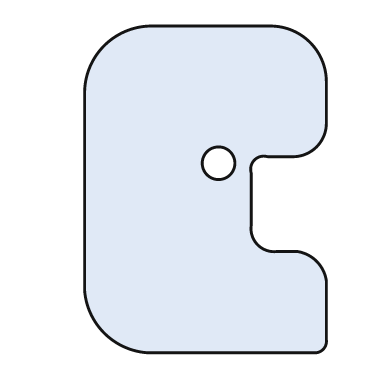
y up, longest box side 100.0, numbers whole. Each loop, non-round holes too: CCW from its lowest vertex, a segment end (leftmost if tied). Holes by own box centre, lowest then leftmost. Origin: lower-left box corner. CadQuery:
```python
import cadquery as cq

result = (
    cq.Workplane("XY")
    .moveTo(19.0, 0.0)
    .lineTo(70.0, 0.0)
    .threePointArc((73.0, 1.0), (74.0, 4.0))
    .lineTo(74.0, 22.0)
    .threePointArc((71.0, 28.0), (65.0, 31.0))
    .lineTo(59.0, 31.0)
    .threePointArc((53.0, 33.0), (51.0, 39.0))
    .lineTo(51.0, 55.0)
    .threePointArc((52.0, 59.0), (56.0, 60.0))
    .lineTo(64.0, 60.0)
    .threePointArc((71.0, 63.0), (74.0, 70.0))
    .lineTo(74.0, 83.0)
    .threePointArc((69.0, 95.0), (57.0, 100.0))
    .lineTo(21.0, 100.0)
    .threePointArc((6.0, 94.0), (0.0, 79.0))
    .lineTo(0.0, 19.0)
    .threePointArc((6.0, 6.0), (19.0, 0.0))
    .close()
    .moveTo(41.0, 58.0)
    .circle(5.0)
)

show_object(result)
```